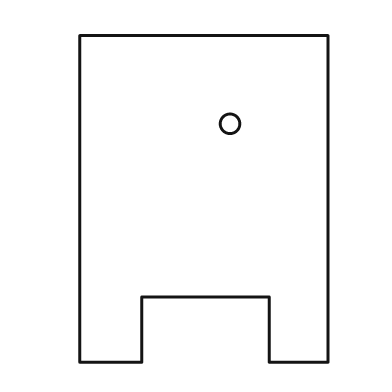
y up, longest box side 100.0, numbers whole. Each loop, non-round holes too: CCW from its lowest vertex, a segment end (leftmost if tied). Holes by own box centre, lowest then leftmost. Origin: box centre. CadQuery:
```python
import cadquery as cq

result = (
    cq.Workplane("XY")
    .moveTo(-38.0, -50.0)
    .lineTo(-19.0, -50.0)
    .lineTo(-19.0, -30.0)
    .lineTo(20.0, -30.0)
    .lineTo(20.0, -50.0)
    .lineTo(38.0, -50.0)
    .lineTo(38.0, 50.0)
    .lineTo(-38.0, 50.0)
    .close()
    .moveTo(8.0, 23.0)
    .circle(3.0)
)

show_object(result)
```